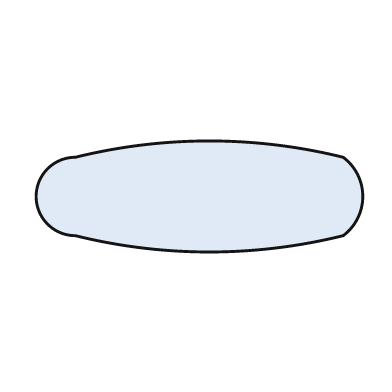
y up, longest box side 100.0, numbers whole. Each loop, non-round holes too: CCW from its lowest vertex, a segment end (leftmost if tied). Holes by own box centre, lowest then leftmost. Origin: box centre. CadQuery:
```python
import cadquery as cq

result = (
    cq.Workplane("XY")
    .moveTo(-38.0, -12.0)
    .threePointArc((3.0, -17.0), (44.0, -12.0))
    .threePointArc((50.0, 0.0), (44.0, 12.0))
    .threePointArc((3.0, 17.0), (-38.0, 12.0))
    .threePointArc((-50.0, 0.0), (-38.0, -12.0))
    .close()
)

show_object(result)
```